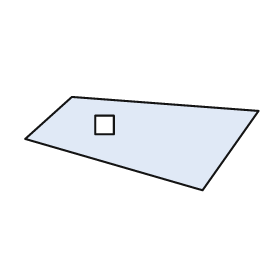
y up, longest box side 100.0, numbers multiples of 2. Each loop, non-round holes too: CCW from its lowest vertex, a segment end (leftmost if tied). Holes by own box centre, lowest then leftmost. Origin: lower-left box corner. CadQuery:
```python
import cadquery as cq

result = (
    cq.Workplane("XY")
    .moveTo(76.0, 0.0)
    .lineTo(100.0, 34.0)
    .lineTo(20.0, 40.0)
    .lineTo(0.0, 22.0)
    .close()
    .moveTo(30.0, 24.0)
    .lineTo(38.0, 24.0)
    .lineTo(38.0, 32.0)
    .lineTo(30.0, 32.0)
    .close()
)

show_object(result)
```